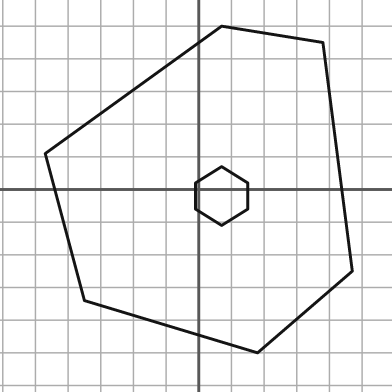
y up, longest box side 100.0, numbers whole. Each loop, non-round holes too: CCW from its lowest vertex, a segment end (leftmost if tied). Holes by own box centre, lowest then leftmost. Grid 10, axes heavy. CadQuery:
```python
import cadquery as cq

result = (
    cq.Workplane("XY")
    .moveTo(18.0, -50.0)
    .lineTo(47.0, -25.0)
    .lineTo(38.0, 45.0)
    .lineTo(7.0, 50.0)
    .lineTo(-47.0, 11.0)
    .lineTo(-35.0, -34.0)
    .close()
    .moveTo(7.0, -11.0)
    .lineTo(15.0, -6.0)
    .lineTo(15.0, 2.0)
    .lineTo(7.0, 7.0)
    .lineTo(-1.0, 2.0)
    .lineTo(-1.0, -6.0)
    .close()
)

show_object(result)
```